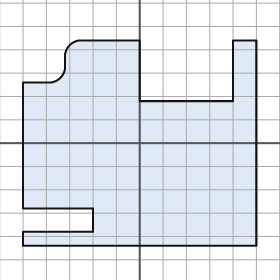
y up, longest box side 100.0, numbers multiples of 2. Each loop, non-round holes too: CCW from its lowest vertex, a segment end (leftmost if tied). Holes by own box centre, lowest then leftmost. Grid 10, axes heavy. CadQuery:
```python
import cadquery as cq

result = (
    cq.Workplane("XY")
    .moveTo(-50.0, -44.0)
    .lineTo(50.0, -44.0)
    .lineTo(50.0, 44.0)
    .lineTo(40.0, 44.0)
    .lineTo(40.0, 18.0)
    .lineTo(0.0, 18.0)
    .lineTo(0.0, 44.0)
    .lineTo(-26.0, 44.0)
    .threePointArc((-30.0, 42.0), (-32.0, 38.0))
    .lineTo(-32.0, 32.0)
    .threePointArc((-34.0, 28.0), (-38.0, 26.0))
    .lineTo(-50.0, 26.0)
    .lineTo(-50.0, -28.0)
    .lineTo(-20.0, -28.0)
    .lineTo(-20.0, -38.0)
    .lineTo(-50.0, -38.0)
    .close()
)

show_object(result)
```